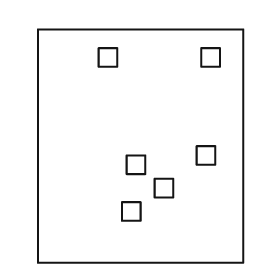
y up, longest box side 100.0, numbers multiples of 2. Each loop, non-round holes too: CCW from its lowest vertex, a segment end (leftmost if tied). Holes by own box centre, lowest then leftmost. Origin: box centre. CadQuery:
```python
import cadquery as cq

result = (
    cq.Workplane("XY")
    .moveTo(-44.0, -50.0)
    .lineTo(44.0, -50.0)
    .lineTo(44.0, 50.0)
    .lineTo(-44.0, 50.0)
    .close()
    .moveTo(-8.0, -32.0)
    .lineTo(0.0, -32.0)
    .lineTo(0.0, -24.0)
    .lineTo(-8.0, -24.0)
    .close()
    .moveTo(6.0, -22.0)
    .lineTo(14.0, -22.0)
    .lineTo(14.0, -14.0)
    .lineTo(6.0, -14.0)
    .close()
    .moveTo(-6.0, -12.0)
    .lineTo(2.0, -12.0)
    .lineTo(2.0, -4.0)
    .lineTo(-6.0, -4.0)
    .close()
    .moveTo(24.0, -8.0)
    .lineTo(32.0, -8.0)
    .lineTo(32.0, 0.0)
    .lineTo(24.0, 0.0)
    .close()
    .moveTo(-18.0, 34.0)
    .lineTo(-10.0, 34.0)
    .lineTo(-10.0, 42.0)
    .lineTo(-18.0, 42.0)
    .close()
    .moveTo(26.0, 34.0)
    .lineTo(34.0, 34.0)
    .lineTo(34.0, 42.0)
    .lineTo(26.0, 42.0)
    .close()
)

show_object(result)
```